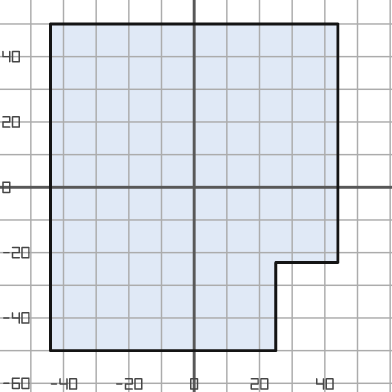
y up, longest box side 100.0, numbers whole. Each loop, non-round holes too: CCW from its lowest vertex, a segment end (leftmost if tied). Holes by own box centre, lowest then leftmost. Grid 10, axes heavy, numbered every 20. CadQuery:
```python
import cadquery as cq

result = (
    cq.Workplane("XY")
    .moveTo(-44.0, -50.0)
    .lineTo(25.0, -50.0)
    .lineTo(25.0, -23.0)
    .lineTo(44.0, -23.0)
    .lineTo(44.0, 50.0)
    .lineTo(-44.0, 50.0)
    .close()
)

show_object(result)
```